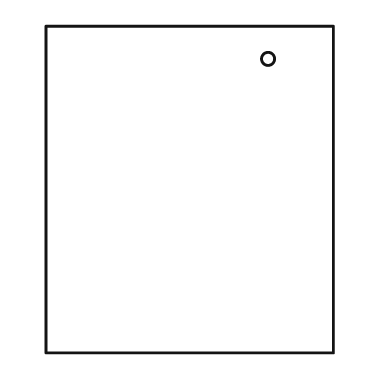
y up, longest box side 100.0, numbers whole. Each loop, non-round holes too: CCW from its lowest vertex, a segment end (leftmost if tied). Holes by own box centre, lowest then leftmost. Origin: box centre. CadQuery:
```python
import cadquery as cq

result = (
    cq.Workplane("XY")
    .moveTo(-44.0, -50.0)
    .lineTo(44.0, -50.0)
    .lineTo(44.0, 50.0)
    .lineTo(-44.0, 50.0)
    .close()
    .moveTo(24.0, 40.0)
    .circle(2.0)
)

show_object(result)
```